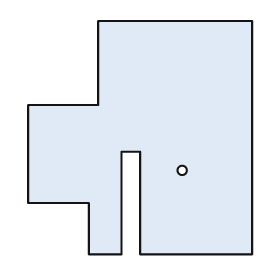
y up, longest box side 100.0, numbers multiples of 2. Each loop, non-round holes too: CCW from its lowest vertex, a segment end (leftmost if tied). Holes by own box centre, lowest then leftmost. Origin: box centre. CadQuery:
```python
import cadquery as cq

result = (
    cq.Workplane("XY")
    .moveTo(-22.0, -50.0)
    .lineTo(-8.0, -50.0)
    .lineTo(-8.0, -6.0)
    .lineTo(0.0, -6.0)
    .lineTo(0.0, -50.0)
    .lineTo(48.0, -50.0)
    .lineTo(48.0, 50.0)
    .lineTo(-18.0, 50.0)
    .lineTo(-18.0, 14.0)
    .lineTo(-48.0, 14.0)
    .lineTo(-48.0, -28.0)
    .lineTo(-22.0, -28.0)
    .close()
    .moveTo(18.0, -14.0)
    .circle(2.0)
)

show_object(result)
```